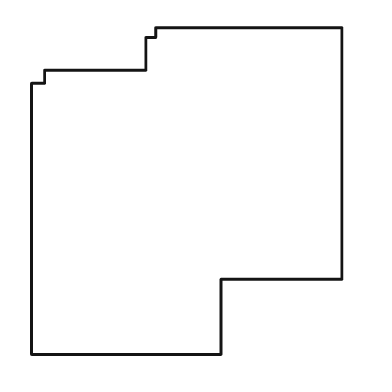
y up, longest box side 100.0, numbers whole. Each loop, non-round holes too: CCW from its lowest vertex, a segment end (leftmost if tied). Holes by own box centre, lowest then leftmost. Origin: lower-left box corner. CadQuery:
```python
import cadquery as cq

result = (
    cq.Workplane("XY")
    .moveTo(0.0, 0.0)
    .lineTo(58.0, 0.0)
    .lineTo(58.0, 23.0)
    .lineTo(95.0, 23.0)
    .lineTo(95.0, 100.0)
    .lineTo(38.0, 100.0)
    .lineTo(38.0, 97.0)
    .lineTo(35.0, 97.0)
    .lineTo(35.0, 87.0)
    .lineTo(4.0, 87.0)
    .lineTo(4.0, 83.0)
    .lineTo(0.0, 83.0)
    .close()
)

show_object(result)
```